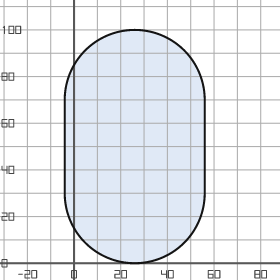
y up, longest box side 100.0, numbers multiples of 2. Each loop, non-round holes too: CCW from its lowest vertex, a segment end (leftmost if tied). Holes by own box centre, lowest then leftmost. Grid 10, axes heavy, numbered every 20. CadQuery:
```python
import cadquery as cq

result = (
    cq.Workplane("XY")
    .moveTo(-4.0, 30.0)
    .threePointArc((26.0, 0.0), (56.0, 30.0))
    .lineTo(56.0, 70.0)
    .threePointArc((26.0, 100.0), (-4.0, 70.0))
    .close()
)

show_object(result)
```